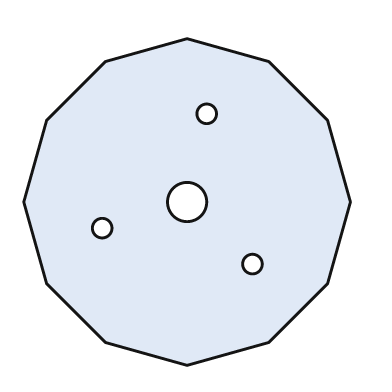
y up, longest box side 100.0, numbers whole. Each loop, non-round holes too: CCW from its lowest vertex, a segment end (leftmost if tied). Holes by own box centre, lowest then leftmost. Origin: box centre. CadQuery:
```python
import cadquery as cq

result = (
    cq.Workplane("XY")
    .moveTo(0.0, -50.0)
    .lineTo(25.0, -43.0)
    .lineTo(43.0, -25.0)
    .lineTo(50.0, 0.0)
    .lineTo(43.0, 25.0)
    .lineTo(25.0, 43.0)
    .lineTo(0.0, 50.0)
    .lineTo(-25.0, 43.0)
    .lineTo(-43.0, 25.0)
    .lineTo(-50.0, 0.0)
    .lineTo(-43.0, -25.0)
    .lineTo(-25.0, -43.0)
    .close()
    .moveTo(20.0, -19.0)
    .circle(3.0)
    .moveTo(-26.0, -8.0)
    .circle(3.0)
    .moveTo(0.0, 0.0)
    .circle(6.0)
    .moveTo(6.0, 27.0)
    .circle(3.0)
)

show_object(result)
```